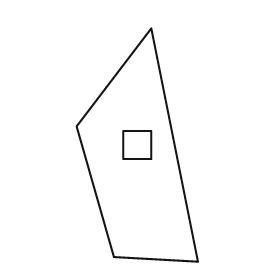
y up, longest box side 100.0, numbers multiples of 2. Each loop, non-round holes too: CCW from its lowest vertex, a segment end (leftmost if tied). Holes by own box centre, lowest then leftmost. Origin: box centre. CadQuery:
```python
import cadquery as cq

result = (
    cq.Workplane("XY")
    .moveTo(26.0, -50.0)
    .lineTo(6.0, 50.0)
    .lineTo(-26.0, 8.0)
    .lineTo(-10.0, -48.0)
    .close()
    .moveTo(-6.0, -6.0)
    .lineTo(6.0, -6.0)
    .lineTo(6.0, 6.0)
    .lineTo(-6.0, 6.0)
    .close()
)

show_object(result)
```